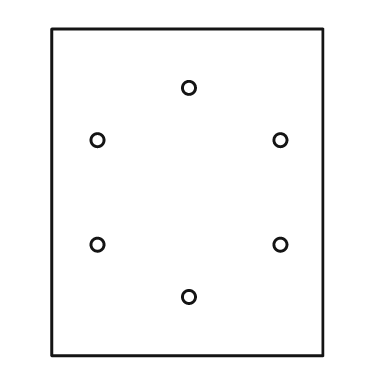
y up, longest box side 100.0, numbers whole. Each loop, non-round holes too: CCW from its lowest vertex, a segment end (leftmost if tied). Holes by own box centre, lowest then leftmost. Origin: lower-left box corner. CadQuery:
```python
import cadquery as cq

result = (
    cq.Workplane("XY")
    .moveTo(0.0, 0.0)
    .lineTo(83.0, 0.0)
    .lineTo(83.0, 100.0)
    .lineTo(0.0, 100.0)
    .close()
    .moveTo(42.0, 18.0)
    .circle(2.0)
    .moveTo(14.0, 34.0)
    .circle(2.0)
    .moveTo(70.0, 34.0)
    .circle(2.0)
    .moveTo(14.0, 66.0)
    .circle(2.0)
    .moveTo(70.0, 66.0)
    .circle(2.0)
    .moveTo(42.0, 82.0)
    .circle(2.0)
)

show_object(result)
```